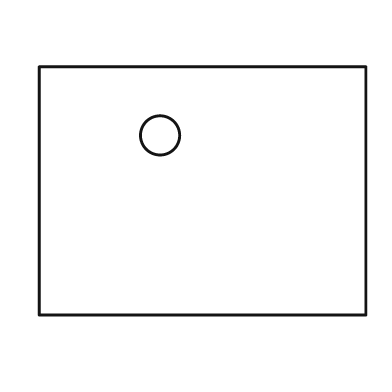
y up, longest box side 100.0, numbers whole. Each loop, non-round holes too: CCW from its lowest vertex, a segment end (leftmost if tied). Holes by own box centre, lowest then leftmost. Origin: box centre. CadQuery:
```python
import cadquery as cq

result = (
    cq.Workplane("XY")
    .moveTo(-50.0, -38.0)
    .lineTo(50.0, -38.0)
    .lineTo(50.0, 38.0)
    .lineTo(-50.0, 38.0)
    .close()
    .moveTo(-13.0, 17.0)
    .circle(6.0)
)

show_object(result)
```